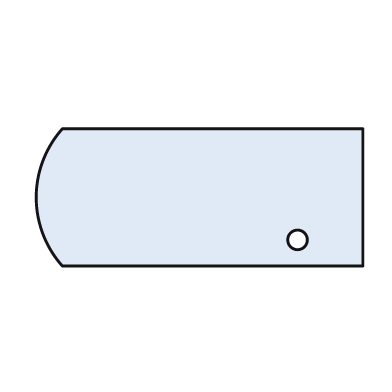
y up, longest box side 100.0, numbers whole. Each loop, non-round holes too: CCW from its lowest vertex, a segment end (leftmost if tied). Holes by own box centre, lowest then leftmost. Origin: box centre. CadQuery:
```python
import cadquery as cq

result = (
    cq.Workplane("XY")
    .moveTo(-42.0, -21.0)
    .lineTo(50.0, -21.0)
    .lineTo(50.0, 21.0)
    .lineTo(-42.0, 21.0)
    .threePointArc((-50.0, 0.0), (-42.0, -21.0))
    .close()
    .moveTo(30.0, -13.0)
    .circle(3.0)
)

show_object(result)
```